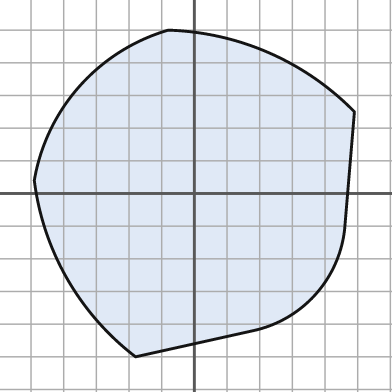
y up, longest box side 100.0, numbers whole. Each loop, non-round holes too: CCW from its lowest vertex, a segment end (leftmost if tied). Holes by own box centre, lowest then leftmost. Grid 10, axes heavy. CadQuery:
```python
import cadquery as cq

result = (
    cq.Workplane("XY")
    .moveTo(-18.0, -50.0)
    .lineTo(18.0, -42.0)
    .threePointArc((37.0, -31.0), (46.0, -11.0))
    .lineTo(49.0, 25.0)
    .threePointArc((23.0, 43.0), (-8.0, 50.0))
    .threePointArc((-35.0, 33.0), (-49.0, 4.0))
    .threePointArc((-39.0, -26.0), (-18.0, -50.0))
    .close()
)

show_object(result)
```